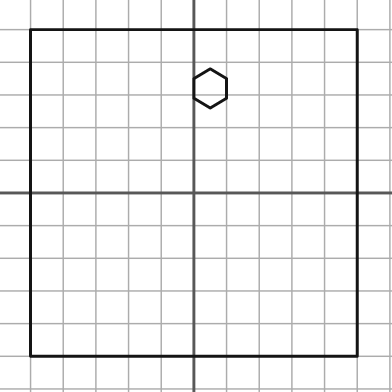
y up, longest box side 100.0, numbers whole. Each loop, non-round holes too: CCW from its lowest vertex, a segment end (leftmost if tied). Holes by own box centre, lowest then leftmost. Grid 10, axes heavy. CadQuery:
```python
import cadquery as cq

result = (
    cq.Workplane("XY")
    .moveTo(-50.0, -50.0)
    .lineTo(50.0, -50.0)
    .lineTo(50.0, 50.0)
    .lineTo(-50.0, 50.0)
    .close()
    .moveTo(5.0, 26.0)
    .lineTo(10.0, 29.0)
    .lineTo(10.0, 35.0)
    .lineTo(5.0, 38.0)
    .lineTo(0.0, 35.0)
    .lineTo(0.0, 29.0)
    .close()
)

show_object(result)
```